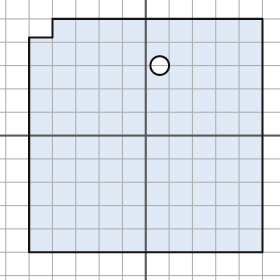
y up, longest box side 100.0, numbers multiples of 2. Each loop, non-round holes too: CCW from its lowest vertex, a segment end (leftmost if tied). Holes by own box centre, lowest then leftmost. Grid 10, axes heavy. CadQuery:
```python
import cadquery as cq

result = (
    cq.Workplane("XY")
    .moveTo(-50.0, -50.0)
    .lineTo(50.0, -50.0)
    .lineTo(50.0, 50.0)
    .lineTo(-40.0, 50.0)
    .lineTo(-40.0, 42.0)
    .lineTo(-50.0, 42.0)
    .close()
    .moveTo(6.0, 30.0)
    .circle(4.0)
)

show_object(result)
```